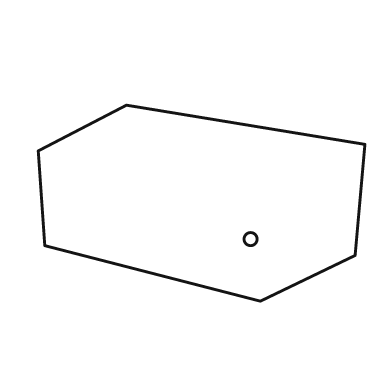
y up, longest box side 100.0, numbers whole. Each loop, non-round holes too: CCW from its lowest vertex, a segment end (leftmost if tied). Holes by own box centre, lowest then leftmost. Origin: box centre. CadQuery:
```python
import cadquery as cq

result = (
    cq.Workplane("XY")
    .moveTo(18.0, -30.0)
    .lineTo(47.0, -16.0)
    .lineTo(50.0, 18.0)
    .lineTo(-23.0, 30.0)
    .lineTo(-50.0, 16.0)
    .lineTo(-48.0, -13.0)
    .close()
    .moveTo(15.0, -11.0)
    .circle(2.0)
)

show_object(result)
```